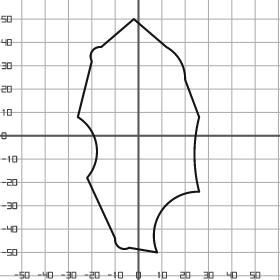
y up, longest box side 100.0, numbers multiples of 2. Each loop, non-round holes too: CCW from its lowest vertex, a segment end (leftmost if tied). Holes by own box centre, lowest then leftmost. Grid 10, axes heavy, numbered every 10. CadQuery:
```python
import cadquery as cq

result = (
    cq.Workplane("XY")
    .moveTo(8.0, -50.0)
    .threePointArc((10.0, -32.0), (26.0, -24.0))
    .threePointArc((24.0, -8.0), (26.0, 8.0))
    .lineTo(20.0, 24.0)
    .threePointArc((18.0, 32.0), (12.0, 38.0))
    .lineTo(-2.0, 50.0)
    .lineTo(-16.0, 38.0)
    .threePointArc((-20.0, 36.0), (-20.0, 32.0))
    .lineTo(-26.0, 8.0)
    .threePointArc((-18.0, -4.0), (-22.0, -18.0))
    .lineTo(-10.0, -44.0)
    .threePointArc((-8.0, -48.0), (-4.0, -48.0))
    .close()
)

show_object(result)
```